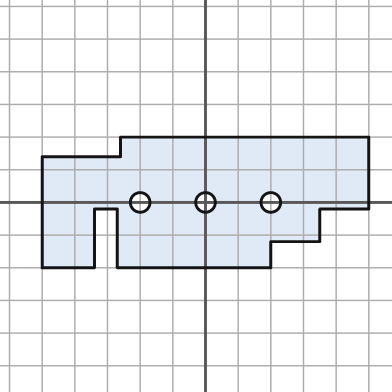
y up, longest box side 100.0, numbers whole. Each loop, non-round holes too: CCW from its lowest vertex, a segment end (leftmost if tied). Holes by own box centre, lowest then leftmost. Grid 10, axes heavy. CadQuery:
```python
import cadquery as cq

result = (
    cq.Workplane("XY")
    .moveTo(-50.0, -20.0)
    .lineTo(-34.0, -20.0)
    .lineTo(-34.0, -2.0)
    .lineTo(-27.0, -2.0)
    .lineTo(-27.0, -20.0)
    .lineTo(20.0, -20.0)
    .lineTo(20.0, -12.0)
    .lineTo(35.0, -12.0)
    .lineTo(35.0, -2.0)
    .lineTo(50.0, -2.0)
    .lineTo(50.0, 20.0)
    .lineTo(-26.0, 20.0)
    .lineTo(-26.0, 14.0)
    .lineTo(-50.0, 14.0)
    .close()
    .moveTo(-20.0, 0.0)
    .circle(3.0)
    .moveTo(0.0, 0.0)
    .circle(3.0)
    .moveTo(20.0, 0.0)
    .circle(3.0)
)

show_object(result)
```